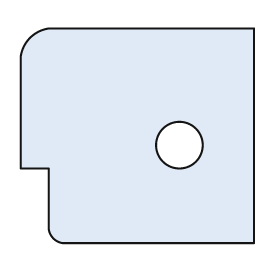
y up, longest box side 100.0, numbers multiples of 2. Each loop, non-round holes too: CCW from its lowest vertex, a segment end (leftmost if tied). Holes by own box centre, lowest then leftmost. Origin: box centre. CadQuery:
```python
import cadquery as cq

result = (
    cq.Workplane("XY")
    .moveTo(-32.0, -46.0)
    .lineTo(50.0, -46.0)
    .lineTo(50.0, 46.0)
    .lineTo(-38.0, 46.0)
    .threePointArc((-46.0, 42.0), (-50.0, 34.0))
    .lineTo(-50.0, -14.0)
    .lineTo(-38.0, -14.0)
    .lineTo(-38.0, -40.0)
    .threePointArc((-36.0, -44.0), (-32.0, -46.0))
    .close()
    .moveTo(18.0, -4.0)
    .circle(10.0)
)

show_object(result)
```